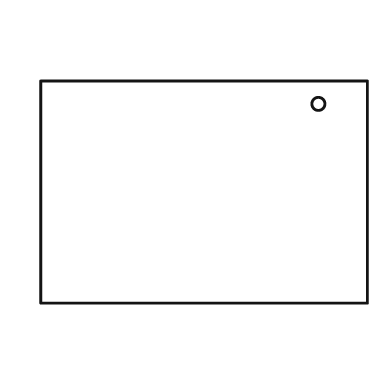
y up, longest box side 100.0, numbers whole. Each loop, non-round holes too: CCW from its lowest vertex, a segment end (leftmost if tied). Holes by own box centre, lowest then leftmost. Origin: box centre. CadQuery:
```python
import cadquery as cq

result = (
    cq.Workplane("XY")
    .moveTo(-50.0, -34.0)
    .lineTo(50.0, -34.0)
    .lineTo(50.0, 34.0)
    .lineTo(-50.0, 34.0)
    .close()
    .moveTo(35.0, 27.0)
    .circle(2.0)
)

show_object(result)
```